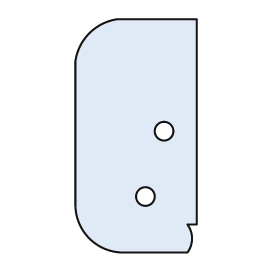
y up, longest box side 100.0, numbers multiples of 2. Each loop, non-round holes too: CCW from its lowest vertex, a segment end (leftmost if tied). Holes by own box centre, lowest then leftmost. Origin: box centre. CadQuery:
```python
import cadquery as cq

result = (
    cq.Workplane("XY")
    .moveTo(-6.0, -50.0)
    .lineTo(22.0, -50.0)
    .threePointArc((24.0, -44.0), (22.0, -38.0))
    .lineTo(26.0, -38.0)
    .lineTo(26.0, 50.0)
    .lineTo(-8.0, 50.0)
    .threePointArc((-20.0, 44.0), (-26.0, 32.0))
    .lineTo(-26.0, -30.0)
    .threePointArc((-20.0, -44.0), (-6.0, -50.0))
    .close()
    .moveTo(4.0, -26.0)
    .circle(4.0)
    .moveTo(12.0, 2.0)
    .circle(4.0)
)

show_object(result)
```